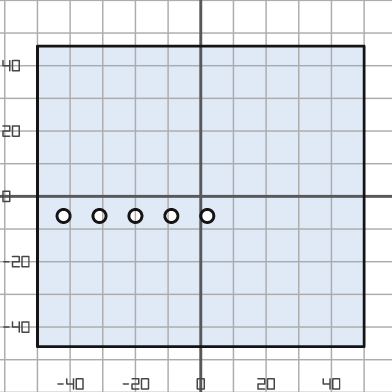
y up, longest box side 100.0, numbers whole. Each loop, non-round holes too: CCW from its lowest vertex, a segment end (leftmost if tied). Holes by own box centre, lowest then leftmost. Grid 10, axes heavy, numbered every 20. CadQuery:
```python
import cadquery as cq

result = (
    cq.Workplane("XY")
    .moveTo(-50.0, -46.0)
    .lineTo(50.0, -46.0)
    .lineTo(50.0, 46.0)
    .lineTo(-50.0, 46.0)
    .close()
    .moveTo(-42.0, -6.0)
    .circle(2.0)
    .moveTo(-31.0, -6.0)
    .circle(2.0)
    .moveTo(-20.0, -6.0)
    .circle(2.0)
    .moveTo(-9.0, -6.0)
    .circle(2.0)
    .moveTo(2.0, -6.0)
    .circle(2.0)
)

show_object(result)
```